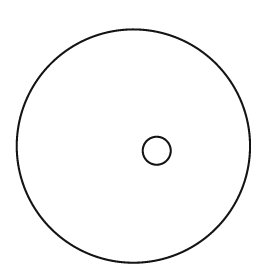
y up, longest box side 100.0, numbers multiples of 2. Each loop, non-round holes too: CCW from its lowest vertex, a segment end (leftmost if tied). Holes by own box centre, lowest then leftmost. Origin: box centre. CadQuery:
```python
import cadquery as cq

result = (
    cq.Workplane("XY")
    .moveTo(0.0, 0.0)
    .circle(50.0)
    .moveTo(10.0, -2.0)
    .circle(6.0)
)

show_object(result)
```